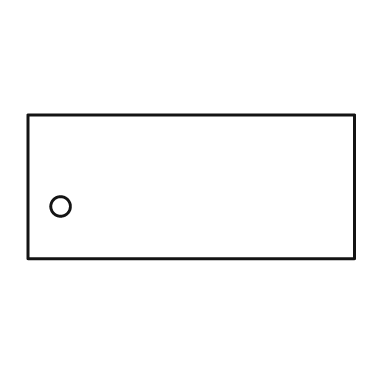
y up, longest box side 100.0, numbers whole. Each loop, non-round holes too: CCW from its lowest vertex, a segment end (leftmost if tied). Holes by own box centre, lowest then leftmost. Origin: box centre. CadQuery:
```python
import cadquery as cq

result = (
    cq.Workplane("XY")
    .moveTo(-50.0, -22.0)
    .lineTo(50.0, -22.0)
    .lineTo(50.0, 22.0)
    .lineTo(-50.0, 22.0)
    .close()
    .moveTo(-40.0, -6.0)
    .circle(3.0)
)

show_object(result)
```